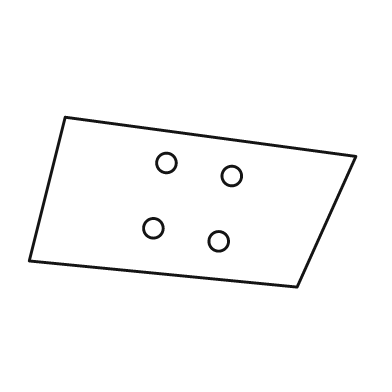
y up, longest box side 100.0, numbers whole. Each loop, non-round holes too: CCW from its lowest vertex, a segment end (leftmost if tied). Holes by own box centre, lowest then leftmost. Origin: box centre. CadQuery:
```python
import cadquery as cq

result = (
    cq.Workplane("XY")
    .moveTo(32.0, -26.0)
    .lineTo(50.0, 14.0)
    .lineTo(-39.0, 26.0)
    .lineTo(-50.0, -18.0)
    .close()
    .moveTo(8.0, -12.0)
    .circle(3.0)
    .moveTo(-12.0, -8.0)
    .circle(3.0)
    .moveTo(12.0, 8.0)
    .circle(3.0)
    .moveTo(-8.0, 12.0)
    .circle(3.0)
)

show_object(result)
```